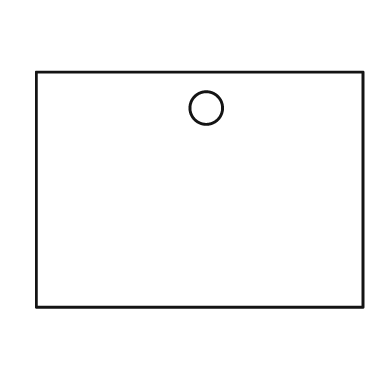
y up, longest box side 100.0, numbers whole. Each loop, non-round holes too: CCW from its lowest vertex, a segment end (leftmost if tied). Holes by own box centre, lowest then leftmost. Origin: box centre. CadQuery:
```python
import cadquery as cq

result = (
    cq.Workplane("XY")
    .moveTo(-50.0, -36.0)
    .lineTo(50.0, -36.0)
    .lineTo(50.0, 36.0)
    .lineTo(-50.0, 36.0)
    .close()
    .moveTo(2.0, 25.0)
    .circle(5.0)
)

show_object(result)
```